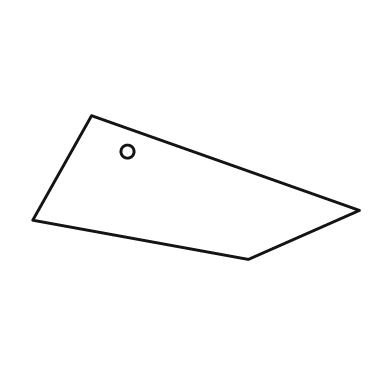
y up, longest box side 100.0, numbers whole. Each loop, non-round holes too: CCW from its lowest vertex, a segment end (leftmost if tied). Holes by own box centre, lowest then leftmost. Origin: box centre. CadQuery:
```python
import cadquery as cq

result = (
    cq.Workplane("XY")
    .moveTo(16.0, -22.0)
    .lineTo(50.0, -7.0)
    .lineTo(-32.0, 22.0)
    .lineTo(-50.0, -10.0)
    .close()
    .moveTo(-21.0, 11.0)
    .circle(2.0)
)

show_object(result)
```